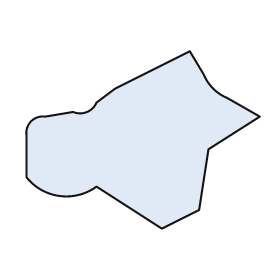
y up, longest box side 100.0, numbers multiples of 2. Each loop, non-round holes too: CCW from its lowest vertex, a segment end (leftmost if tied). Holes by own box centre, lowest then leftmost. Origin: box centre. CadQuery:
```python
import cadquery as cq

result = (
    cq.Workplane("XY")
    .moveTo(8.0, -38.0)
    .lineTo(24.0, -30.0)
    .lineTo(28.0, -4.0)
    .lineTo(50.0, 10.0)
    .lineTo(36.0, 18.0)
    .threePointArc((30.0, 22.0), (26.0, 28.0))
    .lineTo(20.0, 38.0)
    .lineTo(-12.0, 22.0)
    .lineTo(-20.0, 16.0)
    .threePointArc((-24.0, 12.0), (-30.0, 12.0))
    .lineTo(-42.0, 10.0)
    .threePointArc((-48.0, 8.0), (-50.0, 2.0))
    .lineTo(-50.0, -16.0)
    .threePointArc((-36.0, -24.0), (-20.0, -20.0))
    .close()
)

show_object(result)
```